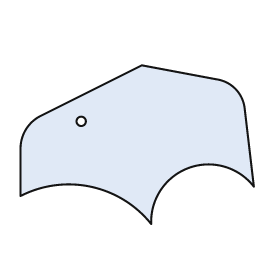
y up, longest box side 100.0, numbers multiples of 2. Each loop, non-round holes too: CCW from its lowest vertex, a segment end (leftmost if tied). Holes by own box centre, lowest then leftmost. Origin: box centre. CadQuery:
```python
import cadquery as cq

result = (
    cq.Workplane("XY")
    .moveTo(6.0, -34.0)
    .threePointArc((22.0, -10.0), (50.0, -18.0))
    .lineTo(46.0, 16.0)
    .threePointArc((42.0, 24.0), (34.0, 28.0))
    .lineTo(2.0, 34.0)
    .lineTo(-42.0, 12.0)
    .threePointArc((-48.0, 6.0), (-50.0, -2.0))
    .lineTo(-50.0, -22.0)
    .threePointArc((-20.0, -18.0), (6.0, -34.0))
    .close()
    .moveTo(-24.0, 10.0)
    .circle(2.0)
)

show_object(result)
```